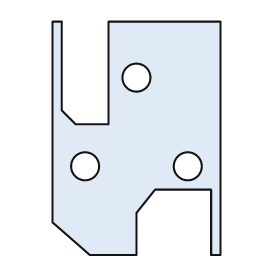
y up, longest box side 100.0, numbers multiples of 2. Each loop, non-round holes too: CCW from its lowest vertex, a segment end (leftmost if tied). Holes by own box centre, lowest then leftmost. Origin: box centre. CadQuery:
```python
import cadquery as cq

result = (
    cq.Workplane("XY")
    .moveTo(-20.0, -50.0)
    .lineTo(0.0, -50.0)
    .lineTo(0.0, -32.0)
    .lineTo(8.0, -22.0)
    .lineTo(32.0, -22.0)
    .lineTo(32.0, -50.0)
    .lineTo(36.0, -50.0)
    .lineTo(36.0, 50.0)
    .lineTo(-12.0, 50.0)
    .lineTo(-12.0, 6.0)
    .lineTo(-26.0, 6.0)
    .lineTo(-32.0, 12.0)
    .lineTo(-32.0, 50.0)
    .lineTo(-36.0, 50.0)
    .lineTo(-36.0, -36.0)
    .close()
    .moveTo(-22.0, -12.0)
    .circle(6.0)
    .moveTo(22.0, -12.0)
    .circle(6.0)
    .moveTo(0.0, 26.0)
    .circle(6.0)
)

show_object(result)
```